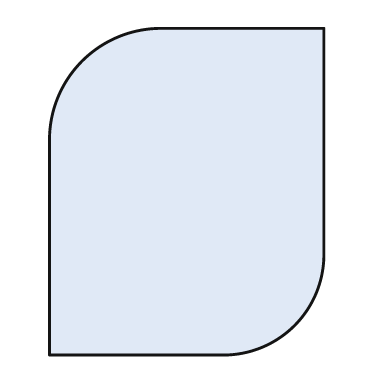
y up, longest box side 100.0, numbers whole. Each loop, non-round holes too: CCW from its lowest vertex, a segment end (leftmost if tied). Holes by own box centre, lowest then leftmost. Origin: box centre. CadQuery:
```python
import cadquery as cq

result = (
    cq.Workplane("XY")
    .moveTo(-42.0, -50.0)
    .lineTo(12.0, -50.0)
    .threePointArc((33.0, -41.0), (42.0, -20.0))
    .lineTo(42.0, 50.0)
    .lineTo(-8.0, 50.0)
    .threePointArc((-32.0, 40.0), (-42.0, 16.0))
    .close()
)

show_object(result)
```